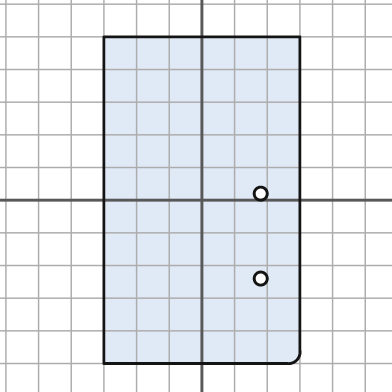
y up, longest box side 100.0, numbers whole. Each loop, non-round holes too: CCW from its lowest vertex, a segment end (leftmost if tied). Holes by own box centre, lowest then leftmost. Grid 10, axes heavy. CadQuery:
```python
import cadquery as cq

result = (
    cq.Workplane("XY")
    .moveTo(-30.0, -50.0)
    .lineTo(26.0, -50.0)
    .threePointArc((29.0, -49.0), (30.0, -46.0))
    .lineTo(30.0, 50.0)
    .lineTo(-30.0, 50.0)
    .close()
    .moveTo(18.0, -24.0)
    .circle(2.0)
    .moveTo(18.0, 2.0)
    .circle(2.0)
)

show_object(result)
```